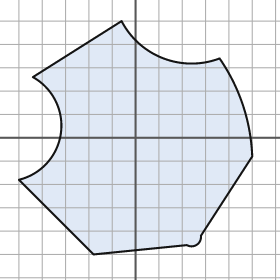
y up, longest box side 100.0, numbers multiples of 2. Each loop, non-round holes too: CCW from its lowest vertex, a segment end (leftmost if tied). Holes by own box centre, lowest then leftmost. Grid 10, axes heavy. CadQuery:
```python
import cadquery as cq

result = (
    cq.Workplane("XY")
    .moveTo(-18.0, -50.0)
    .lineTo(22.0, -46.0)
    .threePointArc((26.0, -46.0), (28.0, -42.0))
    .lineTo(50.0, -8.0)
    .threePointArc((46.0, 14.0), (36.0, 34.0))
    .threePointArc((12.0, 34.0), (-6.0, 50.0))
    .lineTo(-44.0, 26.0)
    .threePointArc((-32.0, 2.0), (-50.0, -18.0))
    .close()
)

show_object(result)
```